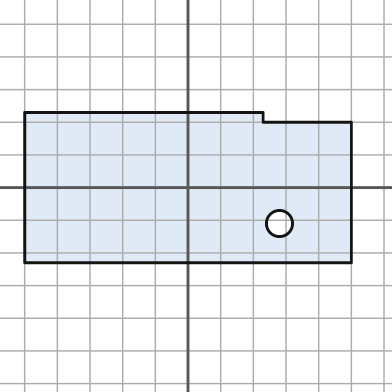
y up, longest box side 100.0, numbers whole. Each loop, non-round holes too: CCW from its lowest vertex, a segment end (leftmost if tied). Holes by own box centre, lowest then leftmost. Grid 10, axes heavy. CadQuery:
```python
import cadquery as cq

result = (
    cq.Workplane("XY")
    .moveTo(-50.0, -23.0)
    .lineTo(50.0, -23.0)
    .lineTo(50.0, 20.0)
    .lineTo(23.0, 20.0)
    .lineTo(23.0, 23.0)
    .lineTo(-50.0, 23.0)
    .close()
    .moveTo(28.0, -11.0)
    .circle(4.0)
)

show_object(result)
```